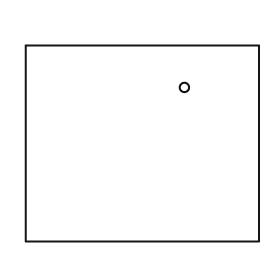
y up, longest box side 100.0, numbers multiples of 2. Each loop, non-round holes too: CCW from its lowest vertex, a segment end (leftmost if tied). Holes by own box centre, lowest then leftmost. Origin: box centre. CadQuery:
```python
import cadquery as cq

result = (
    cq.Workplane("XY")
    .moveTo(-50.0, -42.0)
    .lineTo(50.0, -42.0)
    .lineTo(50.0, 42.0)
    .lineTo(-50.0, 42.0)
    .close()
    .moveTo(18.0, 24.0)
    .circle(2.0)
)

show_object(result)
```